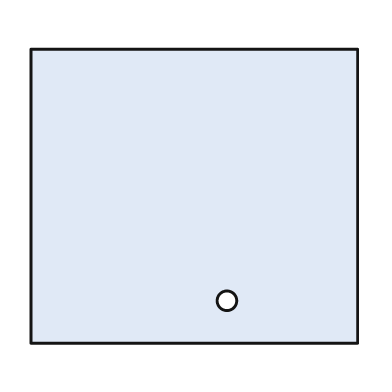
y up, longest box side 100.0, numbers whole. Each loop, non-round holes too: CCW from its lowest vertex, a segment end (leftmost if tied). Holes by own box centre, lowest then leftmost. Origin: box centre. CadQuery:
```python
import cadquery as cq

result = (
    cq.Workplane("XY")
    .moveTo(-50.0, -45.0)
    .lineTo(50.0, -45.0)
    .lineTo(50.0, 45.0)
    .lineTo(-50.0, 45.0)
    .close()
    .moveTo(10.0, -32.0)
    .circle(3.0)
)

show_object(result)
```